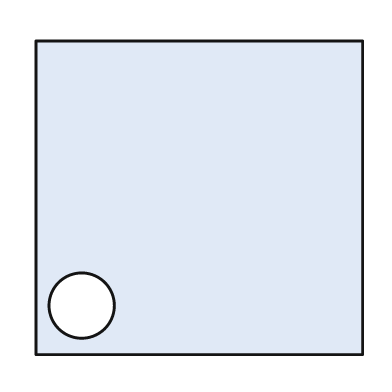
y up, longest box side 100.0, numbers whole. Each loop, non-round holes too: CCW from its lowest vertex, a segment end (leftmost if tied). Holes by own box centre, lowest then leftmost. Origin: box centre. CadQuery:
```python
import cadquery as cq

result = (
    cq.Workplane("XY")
    .moveTo(-50.0, -48.0)
    .lineTo(50.0, -48.0)
    .lineTo(50.0, 48.0)
    .lineTo(-50.0, 48.0)
    .close()
    .moveTo(-36.0, -33.0)
    .circle(10.0)
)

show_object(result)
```